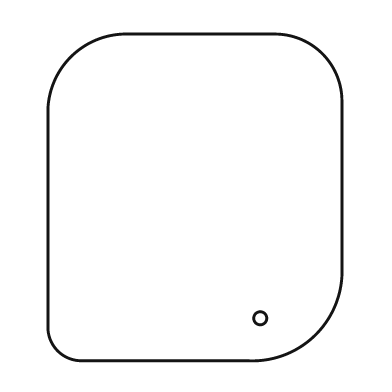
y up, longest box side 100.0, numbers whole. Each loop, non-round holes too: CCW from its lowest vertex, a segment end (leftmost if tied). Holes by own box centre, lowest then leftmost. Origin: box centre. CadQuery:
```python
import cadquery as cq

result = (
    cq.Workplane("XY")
    .moveTo(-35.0, -50.0)
    .lineTo(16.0, -50.0)
    .threePointArc((37.0, -42.0), (45.0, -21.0))
    .lineTo(45.0, 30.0)
    .threePointArc((39.0, 44.0), (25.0, 50.0))
    .lineTo(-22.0, 50.0)
    .threePointArc((-38.0, 43.0), (-45.0, 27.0))
    .lineTo(-45.0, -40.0)
    .threePointArc((-42.0, -47.0), (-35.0, -50.0))
    .close()
    .moveTo(20.0, -37.0)
    .circle(2.0)
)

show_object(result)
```